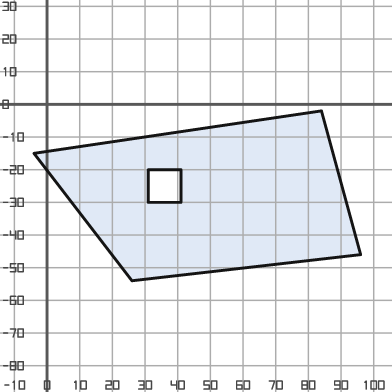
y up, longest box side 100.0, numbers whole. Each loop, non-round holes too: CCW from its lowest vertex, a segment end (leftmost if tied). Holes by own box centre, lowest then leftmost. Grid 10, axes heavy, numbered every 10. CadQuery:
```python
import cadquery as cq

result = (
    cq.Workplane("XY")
    .moveTo(26.0, -54.0)
    .lineTo(96.0, -46.0)
    .lineTo(84.0, -2.0)
    .lineTo(-4.0, -15.0)
    .close()
    .moveTo(31.0, -30.0)
    .lineTo(41.0, -30.0)
    .lineTo(41.0, -20.0)
    .lineTo(31.0, -20.0)
    .close()
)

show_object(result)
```